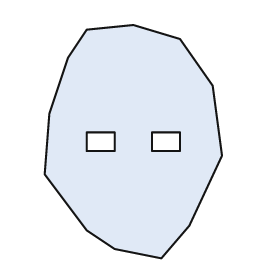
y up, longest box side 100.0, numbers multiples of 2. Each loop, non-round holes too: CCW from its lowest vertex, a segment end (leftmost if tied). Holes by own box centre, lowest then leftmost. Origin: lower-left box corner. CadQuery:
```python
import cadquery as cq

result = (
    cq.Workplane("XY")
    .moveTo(50.0, 0.0)
    .lineTo(62.0, 14.0)
    .lineTo(76.0, 44.0)
    .lineTo(72.0, 74.0)
    .lineTo(58.0, 94.0)
    .lineTo(38.0, 100.0)
    .lineTo(18.0, 98.0)
    .lineTo(10.0, 86.0)
    .lineTo(2.0, 62.0)
    .lineTo(0.0, 36.0)
    .lineTo(18.0, 12.0)
    .lineTo(30.0, 4.0)
    .close()
    .moveTo(18.0, 46.0)
    .lineTo(30.0, 46.0)
    .lineTo(30.0, 54.0)
    .lineTo(18.0, 54.0)
    .close()
    .moveTo(46.0, 46.0)
    .lineTo(58.0, 46.0)
    .lineTo(58.0, 54.0)
    .lineTo(46.0, 54.0)
    .close()
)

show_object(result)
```